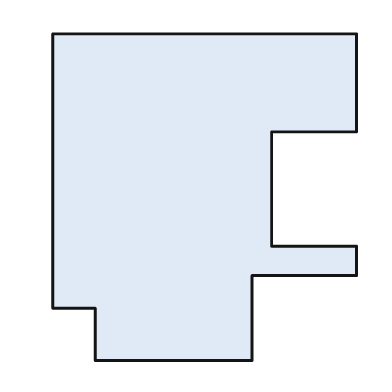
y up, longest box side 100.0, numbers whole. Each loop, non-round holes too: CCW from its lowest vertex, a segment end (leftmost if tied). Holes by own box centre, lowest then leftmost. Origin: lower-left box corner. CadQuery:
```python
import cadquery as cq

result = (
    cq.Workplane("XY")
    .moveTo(13.0, 0.0)
    .lineTo(61.0, 0.0)
    .lineTo(61.0, 26.0)
    .lineTo(93.0, 26.0)
    .lineTo(93.0, 35.0)
    .lineTo(67.0, 35.0)
    .lineTo(67.0, 70.0)
    .lineTo(93.0, 70.0)
    .lineTo(93.0, 100.0)
    .lineTo(0.0, 100.0)
    .lineTo(0.0, 16.0)
    .lineTo(13.0, 16.0)
    .close()
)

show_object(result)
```